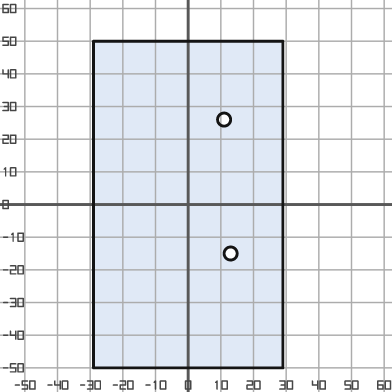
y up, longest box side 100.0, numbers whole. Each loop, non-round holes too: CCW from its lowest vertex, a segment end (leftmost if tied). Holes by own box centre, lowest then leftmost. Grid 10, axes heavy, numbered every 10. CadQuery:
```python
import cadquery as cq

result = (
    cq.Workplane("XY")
    .moveTo(-29.0, -50.0)
    .lineTo(29.0, -50.0)
    .lineTo(29.0, 50.0)
    .lineTo(-29.0, 50.0)
    .close()
    .moveTo(13.0, -15.0)
    .circle(2.0)
    .moveTo(11.0, 26.0)
    .circle(2.0)
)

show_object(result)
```